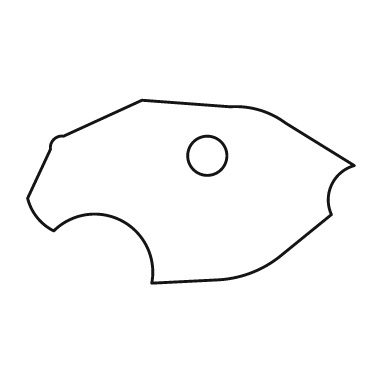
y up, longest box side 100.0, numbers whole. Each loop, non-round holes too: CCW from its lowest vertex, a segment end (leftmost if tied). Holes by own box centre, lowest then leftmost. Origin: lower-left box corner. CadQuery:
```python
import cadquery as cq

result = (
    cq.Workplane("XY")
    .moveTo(38.0, 0.0)
    .lineTo(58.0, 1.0)
    .threePointArc((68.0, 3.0), (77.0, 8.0))
    .lineTo(93.0, 21.0)
    .threePointArc((93.0, 30.0), (100.0, 36.0))
    .lineTo(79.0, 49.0)
    .threePointArc((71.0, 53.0), (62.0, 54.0))
    .lineTo(35.0, 56.0)
    .lineTo(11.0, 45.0)
    .threePointArc((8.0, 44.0), (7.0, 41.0))
    .lineTo(0.0, 26.0)
    .threePointArc((3.0, 20.0), (8.0, 16.0))
    .threePointArc((29.0, 19.0), (38.0, 0.0))
    .close()
    .moveTo(55.0, 39.0)
    .circle(6.0)
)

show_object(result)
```